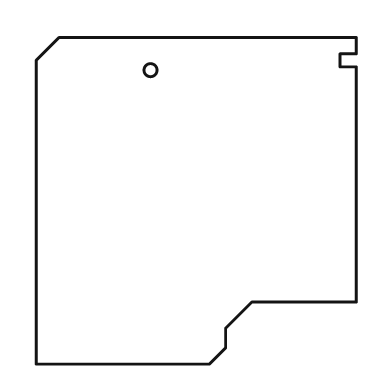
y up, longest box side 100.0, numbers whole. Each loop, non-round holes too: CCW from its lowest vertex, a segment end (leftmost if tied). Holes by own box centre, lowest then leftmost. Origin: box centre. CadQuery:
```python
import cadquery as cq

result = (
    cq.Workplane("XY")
    .moveTo(-49.0, -50.0)
    .lineTo(4.0, -50.0)
    .lineTo(9.0, -45.0)
    .lineTo(9.0, -39.0)
    .lineTo(17.0, -31.0)
    .lineTo(49.0, -31.0)
    .lineTo(49.0, 41.0)
    .lineTo(44.0, 41.0)
    .lineTo(44.0, 45.0)
    .lineTo(49.0, 45.0)
    .lineTo(49.0, 50.0)
    .lineTo(-42.0, 50.0)
    .lineTo(-49.0, 43.0)
    .close()
    .moveTo(-14.0, 40.0)
    .circle(2.0)
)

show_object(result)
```